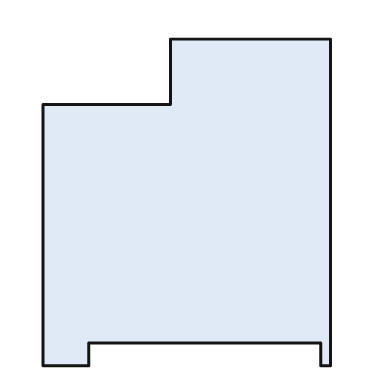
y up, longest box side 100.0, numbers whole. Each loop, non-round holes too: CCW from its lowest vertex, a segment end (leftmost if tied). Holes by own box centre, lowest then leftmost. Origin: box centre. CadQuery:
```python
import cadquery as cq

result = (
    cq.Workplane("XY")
    .moveTo(-44.0, -50.0)
    .lineTo(-30.0, -50.0)
    .lineTo(-30.0, -43.0)
    .lineTo(41.0, -43.0)
    .lineTo(41.0, -50.0)
    .lineTo(44.0, -50.0)
    .lineTo(44.0, 50.0)
    .lineTo(-5.0, 50.0)
    .lineTo(-5.0, 30.0)
    .lineTo(-44.0, 30.0)
    .close()
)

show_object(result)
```